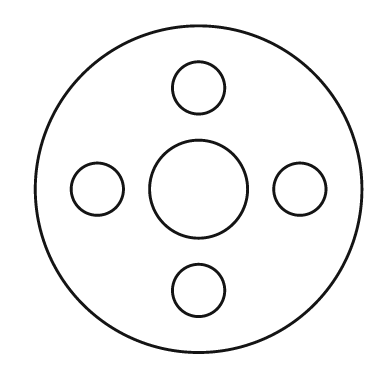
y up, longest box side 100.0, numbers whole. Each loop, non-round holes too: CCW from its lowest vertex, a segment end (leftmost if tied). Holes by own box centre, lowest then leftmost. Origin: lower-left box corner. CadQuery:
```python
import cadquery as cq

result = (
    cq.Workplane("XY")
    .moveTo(50.0, 50.0)
    .circle(50.0)
    .moveTo(50.0, 19.0)
    .circle(8.0)
    .moveTo(19.0, 50.0)
    .circle(8.0)
    .moveTo(50.0, 50.0)
    .circle(15.0)
    .moveTo(81.0, 50.0)
    .circle(8.0)
    .moveTo(50.0, 81.0)
    .circle(8.0)
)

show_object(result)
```